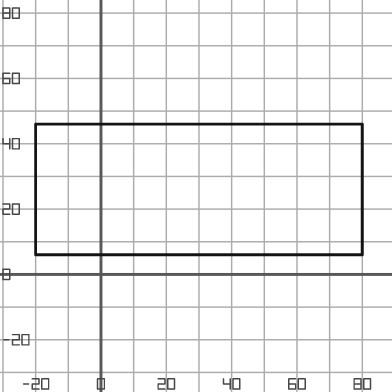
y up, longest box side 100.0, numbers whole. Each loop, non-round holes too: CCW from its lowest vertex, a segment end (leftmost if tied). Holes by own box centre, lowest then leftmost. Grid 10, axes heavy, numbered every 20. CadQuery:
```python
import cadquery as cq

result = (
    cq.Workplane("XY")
    .moveTo(-20.0, 6.0)
    .lineTo(80.0, 6.0)
    .lineTo(80.0, 46.0)
    .lineTo(-20.0, 46.0)
    .close()
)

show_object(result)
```